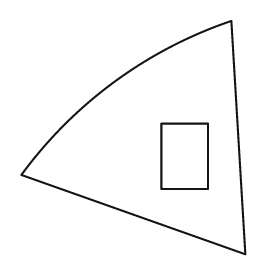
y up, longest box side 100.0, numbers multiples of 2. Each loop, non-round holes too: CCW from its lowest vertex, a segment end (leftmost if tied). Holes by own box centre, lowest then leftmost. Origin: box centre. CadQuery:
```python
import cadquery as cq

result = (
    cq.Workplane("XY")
    .moveTo(48.0, -50.0)
    .lineTo(42.0, 50.0)
    .threePointArc((-8.0, 24.0), (-48.0, -16.0))
    .close()
    .moveTo(12.0, -22.0)
    .lineTo(32.0, -22.0)
    .lineTo(32.0, 6.0)
    .lineTo(12.0, 6.0)
    .close()
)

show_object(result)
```